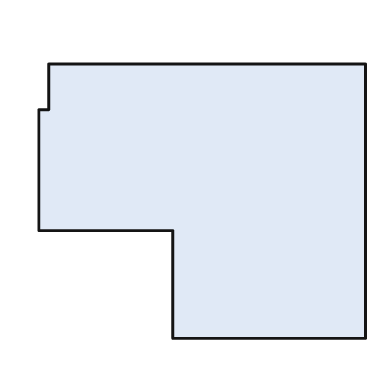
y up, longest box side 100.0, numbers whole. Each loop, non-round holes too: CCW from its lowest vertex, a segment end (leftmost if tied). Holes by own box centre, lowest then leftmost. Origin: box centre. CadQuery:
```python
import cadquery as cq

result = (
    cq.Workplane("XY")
    .moveTo(-9.0, -42.0)
    .lineTo(50.0, -42.0)
    .lineTo(50.0, 42.0)
    .lineTo(-47.0, 42.0)
    .lineTo(-47.0, 28.0)
    .lineTo(-50.0, 28.0)
    .lineTo(-50.0, -9.0)
    .lineTo(-9.0, -9.0)
    .close()
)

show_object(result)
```